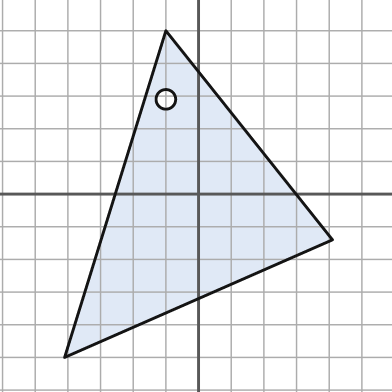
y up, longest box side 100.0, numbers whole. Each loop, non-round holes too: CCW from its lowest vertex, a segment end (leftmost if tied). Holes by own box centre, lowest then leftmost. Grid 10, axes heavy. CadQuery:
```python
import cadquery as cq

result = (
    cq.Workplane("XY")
    .moveTo(-41.0, -50.0)
    .lineTo(41.0, -14.0)
    .lineTo(-10.0, 50.0)
    .close()
    .moveTo(-10.0, 29.0)
    .circle(3.0)
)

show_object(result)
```